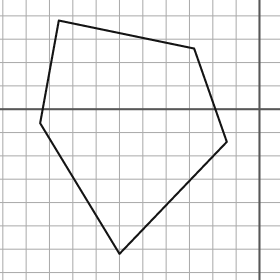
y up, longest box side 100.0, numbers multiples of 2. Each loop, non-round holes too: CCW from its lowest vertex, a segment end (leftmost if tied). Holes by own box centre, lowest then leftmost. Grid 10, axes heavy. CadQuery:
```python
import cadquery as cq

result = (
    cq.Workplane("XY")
    .moveTo(-60.0, -62.0)
    .lineTo(-14.0, -14.0)
    .lineTo(-28.0, 26.0)
    .lineTo(-86.0, 38.0)
    .lineTo(-94.0, -6.0)
    .close()
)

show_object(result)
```